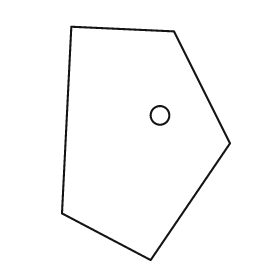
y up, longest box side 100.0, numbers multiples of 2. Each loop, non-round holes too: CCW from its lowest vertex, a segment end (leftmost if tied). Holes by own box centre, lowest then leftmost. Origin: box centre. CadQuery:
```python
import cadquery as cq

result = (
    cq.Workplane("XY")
    .moveTo(2.0, -50.0)
    .lineTo(36.0, 0.0)
    .lineTo(12.0, 48.0)
    .lineTo(-32.0, 50.0)
    .lineTo(-36.0, -30.0)
    .close()
    .moveTo(6.0, 12.0)
    .circle(4.0)
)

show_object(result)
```